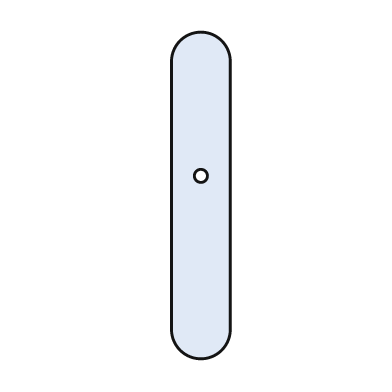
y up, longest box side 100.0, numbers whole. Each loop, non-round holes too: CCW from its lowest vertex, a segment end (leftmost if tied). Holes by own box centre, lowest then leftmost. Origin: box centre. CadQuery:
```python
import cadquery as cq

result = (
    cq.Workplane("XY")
    .moveTo(-9.0, -41.0)
    .threePointArc((0.0, -50.0), (9.0, -41.0))
    .lineTo(9.0, 41.0)
    .threePointArc((0.0, 50.0), (-9.0, 41.0))
    .close()
    .moveTo(0.0, 6.0)
    .circle(2.0)
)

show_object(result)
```